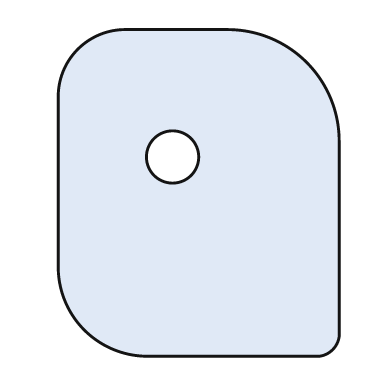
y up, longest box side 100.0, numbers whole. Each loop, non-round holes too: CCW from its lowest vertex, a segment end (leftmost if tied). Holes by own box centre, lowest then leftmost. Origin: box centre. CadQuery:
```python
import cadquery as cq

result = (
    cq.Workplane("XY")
    .moveTo(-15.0, -50.0)
    .lineTo(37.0, -50.0)
    .threePointArc((41.0, -48.0), (43.0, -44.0))
    .lineTo(43.0, 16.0)
    .threePointArc((33.0, 40.0), (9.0, 50.0))
    .lineTo(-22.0, 50.0)
    .threePointArc((-37.0, 44.0), (-43.0, 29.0))
    .lineTo(-43.0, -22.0)
    .threePointArc((-35.0, -42.0), (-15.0, -50.0))
    .close()
    .moveTo(-8.0, 11.0)
    .circle(8.0)
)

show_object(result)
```